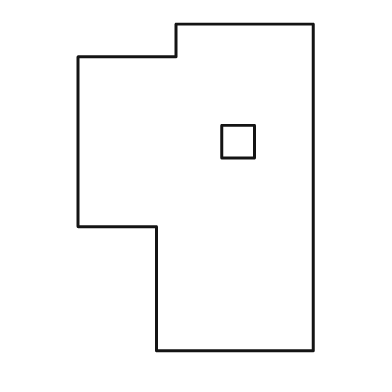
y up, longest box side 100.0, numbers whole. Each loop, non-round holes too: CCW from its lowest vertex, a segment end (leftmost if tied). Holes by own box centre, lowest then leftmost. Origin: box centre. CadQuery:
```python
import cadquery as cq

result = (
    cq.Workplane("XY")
    .moveTo(-12.0, -50.0)
    .lineTo(36.0, -50.0)
    .lineTo(36.0, 50.0)
    .lineTo(-6.0, 50.0)
    .lineTo(-6.0, 40.0)
    .lineTo(-36.0, 40.0)
    .lineTo(-36.0, -12.0)
    .lineTo(-12.0, -12.0)
    .close()
    .moveTo(8.0, 9.0)
    .lineTo(18.0, 9.0)
    .lineTo(18.0, 19.0)
    .lineTo(8.0, 19.0)
    .close()
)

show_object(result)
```